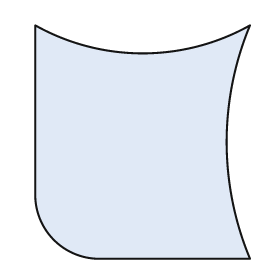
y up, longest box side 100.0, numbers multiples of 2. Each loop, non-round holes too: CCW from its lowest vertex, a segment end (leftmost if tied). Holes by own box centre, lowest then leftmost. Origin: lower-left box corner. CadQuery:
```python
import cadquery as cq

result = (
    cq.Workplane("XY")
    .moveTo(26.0, 0.0)
    .lineTo(92.0, 0.0)
    .threePointArc((82.0, 50.0), (92.0, 100.0))
    .threePointArc((46.0, 88.0), (0.0, 100.0))
    .lineTo(0.0, 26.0)
    .threePointArc((8.0, 8.0), (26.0, 0.0))
    .close()
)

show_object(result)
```